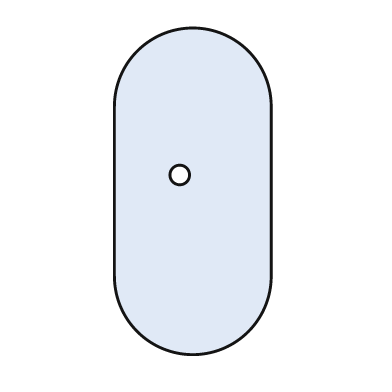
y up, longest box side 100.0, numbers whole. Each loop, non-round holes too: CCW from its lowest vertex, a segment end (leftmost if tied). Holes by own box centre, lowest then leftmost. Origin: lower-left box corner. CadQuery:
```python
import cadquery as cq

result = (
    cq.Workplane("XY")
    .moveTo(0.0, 24.0)
    .threePointArc((24.0, 0.0), (48.0, 24.0))
    .lineTo(48.0, 76.0)
    .threePointArc((24.0, 100.0), (0.0, 76.0))
    .close()
    .moveTo(20.0, 55.0)
    .circle(3.0)
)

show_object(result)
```